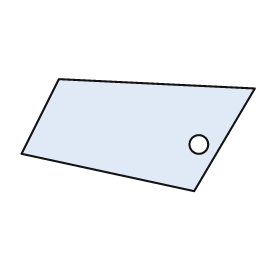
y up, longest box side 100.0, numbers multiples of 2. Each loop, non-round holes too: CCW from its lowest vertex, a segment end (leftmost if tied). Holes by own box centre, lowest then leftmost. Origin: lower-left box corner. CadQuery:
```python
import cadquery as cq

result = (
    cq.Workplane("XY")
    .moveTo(74.0, 0.0)
    .lineTo(100.0, 44.0)
    .lineTo(16.0, 48.0)
    .lineTo(0.0, 16.0)
    .close()
    .moveTo(76.0, 20.0)
    .circle(4.0)
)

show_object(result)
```